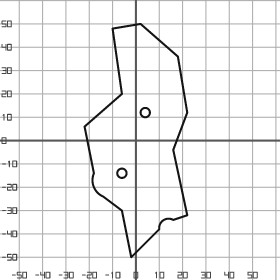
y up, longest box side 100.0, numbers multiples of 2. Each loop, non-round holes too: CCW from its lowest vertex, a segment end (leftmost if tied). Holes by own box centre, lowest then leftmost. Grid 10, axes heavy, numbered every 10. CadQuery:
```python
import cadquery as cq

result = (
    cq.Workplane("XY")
    .moveTo(-2.0, -50.0)
    .lineTo(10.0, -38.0)
    .threePointArc((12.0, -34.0), (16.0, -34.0))
    .lineTo(22.0, -32.0)
    .lineTo(16.0, -4.0)
    .lineTo(22.0, 12.0)
    .lineTo(18.0, 36.0)
    .lineTo(2.0, 50.0)
    .lineTo(-10.0, 48.0)
    .lineTo(-6.0, 20.0)
    .lineTo(-22.0, 6.0)
    .lineTo(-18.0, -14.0)
    .threePointArc((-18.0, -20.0), (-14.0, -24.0))
    .lineTo(-6.0, -30.0)
    .close()
    .moveTo(-6.0, -14.0)
    .circle(2.0)
    .moveTo(4.0, 12.0)
    .circle(2.0)
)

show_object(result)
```